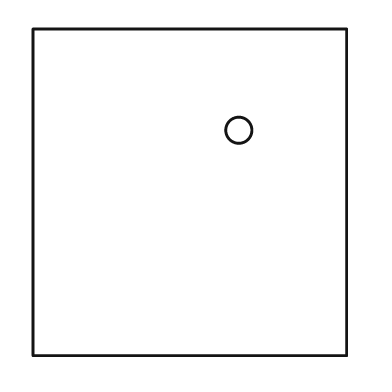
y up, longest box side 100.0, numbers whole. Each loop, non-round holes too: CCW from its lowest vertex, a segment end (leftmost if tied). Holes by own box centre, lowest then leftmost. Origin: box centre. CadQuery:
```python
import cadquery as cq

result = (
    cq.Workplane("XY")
    .moveTo(-48.0, -50.0)
    .lineTo(48.0, -50.0)
    .lineTo(48.0, 50.0)
    .lineTo(-48.0, 50.0)
    .close()
    .moveTo(15.0, 19.0)
    .circle(4.0)
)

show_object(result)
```